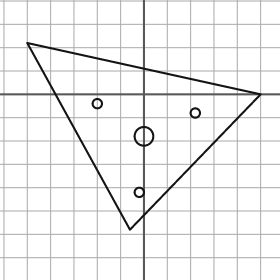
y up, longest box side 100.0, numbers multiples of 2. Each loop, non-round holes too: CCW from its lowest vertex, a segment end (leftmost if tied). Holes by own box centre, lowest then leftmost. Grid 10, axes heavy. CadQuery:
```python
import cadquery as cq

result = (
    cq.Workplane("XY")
    .moveTo(-6.0, -58.0)
    .lineTo(50.0, 0.0)
    .lineTo(-50.0, 22.0)
    .close()
    .moveTo(-2.0, -42.0)
    .circle(2.0)
    .moveTo(0.0, -18.0)
    .circle(4.0)
    .moveTo(22.0, -8.0)
    .circle(2.0)
    .moveTo(-20.0, -4.0)
    .circle(2.0)
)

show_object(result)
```